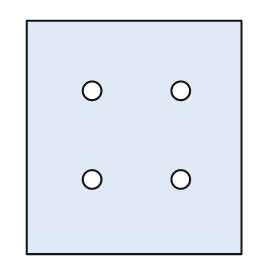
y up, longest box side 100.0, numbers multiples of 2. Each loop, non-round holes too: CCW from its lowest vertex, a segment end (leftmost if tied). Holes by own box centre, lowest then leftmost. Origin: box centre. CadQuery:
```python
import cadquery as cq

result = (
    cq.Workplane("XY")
    .moveTo(-46.0, -50.0)
    .lineTo(46.0, -50.0)
    .lineTo(46.0, 50.0)
    .lineTo(-46.0, 50.0)
    .close()
    .moveTo(-18.0, -18.0)
    .circle(4.0)
    .moveTo(20.0, -18.0)
    .circle(4.0)
    .moveTo(-18.0, 20.0)
    .circle(4.0)
    .moveTo(20.0, 20.0)
    .circle(4.0)
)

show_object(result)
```